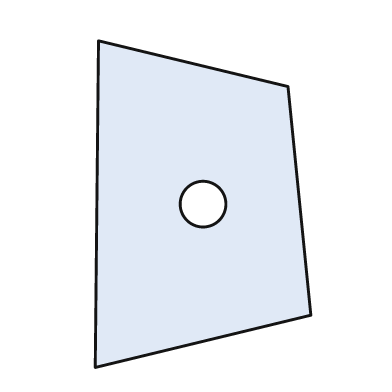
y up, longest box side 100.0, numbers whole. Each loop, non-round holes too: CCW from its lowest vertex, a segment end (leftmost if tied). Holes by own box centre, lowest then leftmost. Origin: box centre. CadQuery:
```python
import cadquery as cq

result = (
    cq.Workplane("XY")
    .moveTo(-33.0, -50.0)
    .lineTo(33.0, -34.0)
    .lineTo(26.0, 36.0)
    .lineTo(-32.0, 50.0)
    .close()
    .moveTo(0.0, 0.0)
    .circle(7.0)
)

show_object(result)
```